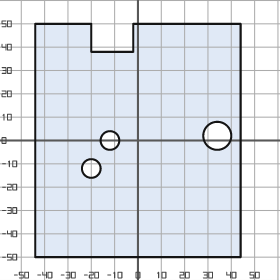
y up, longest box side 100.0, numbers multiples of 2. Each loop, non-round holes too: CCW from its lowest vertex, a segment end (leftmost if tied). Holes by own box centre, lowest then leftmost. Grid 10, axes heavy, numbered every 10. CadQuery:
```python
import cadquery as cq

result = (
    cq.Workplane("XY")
    .moveTo(-44.0, -50.0)
    .lineTo(44.0, -50.0)
    .lineTo(44.0, 50.0)
    .lineTo(-2.0, 50.0)
    .lineTo(-2.0, 38.0)
    .lineTo(-20.0, 38.0)
    .lineTo(-20.0, 50.0)
    .lineTo(-44.0, 50.0)
    .close()
    .moveTo(-20.0, -12.0)
    .circle(4.0)
    .moveTo(-12.0, 0.0)
    .circle(4.0)
    .moveTo(34.0, 2.0)
    .circle(6.0)
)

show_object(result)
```